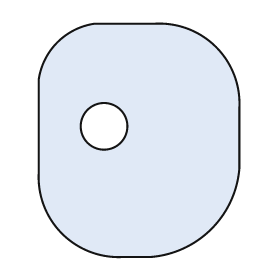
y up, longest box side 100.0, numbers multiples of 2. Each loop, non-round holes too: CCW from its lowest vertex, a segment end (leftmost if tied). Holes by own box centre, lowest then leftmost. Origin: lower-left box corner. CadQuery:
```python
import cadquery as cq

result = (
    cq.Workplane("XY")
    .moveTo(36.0, 0.0)
    .lineTo(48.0, 0.0)
    .threePointArc((74.0, 12.0), (86.0, 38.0))
    .lineTo(86.0, 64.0)
    .threePointArc((76.0, 90.0), (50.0, 100.0))
    .lineTo(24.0, 100.0)
    .threePointArc((8.0, 92.0), (0.0, 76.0))
    .lineTo(0.0, 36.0)
    .threePointArc((10.0, 10.0), (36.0, 0.0))
    .close()
    .moveTo(28.0, 56.0)
    .circle(10.0)
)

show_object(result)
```